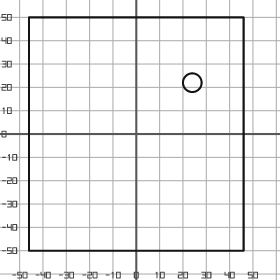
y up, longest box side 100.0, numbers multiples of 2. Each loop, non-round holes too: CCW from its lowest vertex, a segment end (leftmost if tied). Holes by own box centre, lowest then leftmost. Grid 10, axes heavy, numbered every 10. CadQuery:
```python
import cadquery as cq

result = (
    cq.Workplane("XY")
    .moveTo(-46.0, -50.0)
    .lineTo(46.0, -50.0)
    .lineTo(46.0, 50.0)
    .lineTo(-46.0, 50.0)
    .close()
    .moveTo(24.0, 22.0)
    .circle(4.0)
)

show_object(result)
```